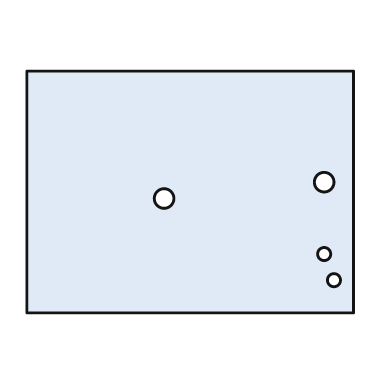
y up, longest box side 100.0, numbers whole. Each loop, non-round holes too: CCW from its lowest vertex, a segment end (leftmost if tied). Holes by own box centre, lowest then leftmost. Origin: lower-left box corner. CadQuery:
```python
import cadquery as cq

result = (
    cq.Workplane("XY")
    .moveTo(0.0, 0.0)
    .lineTo(100.0, 0.0)
    .lineTo(100.0, 74.0)
    .lineTo(0.0, 74.0)
    .close()
    .moveTo(94.0, 10.0)
    .circle(2.0)
    .moveTo(91.0, 18.0)
    .circle(2.0)
    .moveTo(42.0, 35.0)
    .circle(3.0)
    .moveTo(91.0, 40.0)
    .circle(3.0)
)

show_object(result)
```